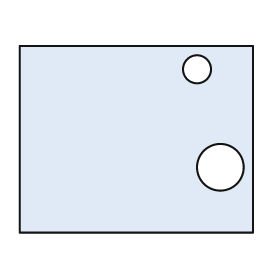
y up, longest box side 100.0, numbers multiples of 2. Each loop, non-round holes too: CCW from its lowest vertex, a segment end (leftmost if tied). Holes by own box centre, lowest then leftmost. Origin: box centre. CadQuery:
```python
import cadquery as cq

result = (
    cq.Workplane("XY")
    .moveTo(-50.0, -40.0)
    .lineTo(50.0, -40.0)
    .lineTo(50.0, 40.0)
    .lineTo(-50.0, 40.0)
    .close()
    .moveTo(36.0, -12.0)
    .circle(10.0)
    .moveTo(26.0, 30.0)
    .circle(6.0)
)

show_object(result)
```